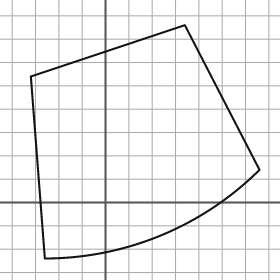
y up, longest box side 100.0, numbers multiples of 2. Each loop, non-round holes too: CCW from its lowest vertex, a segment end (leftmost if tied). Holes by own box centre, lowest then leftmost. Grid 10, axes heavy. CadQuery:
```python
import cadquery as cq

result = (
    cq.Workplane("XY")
    .moveTo(-26.0, -24.0)
    .threePointArc((24.0, -14.0), (66.0, 14.0))
    .lineTo(34.0, 76.0)
    .lineTo(-32.0, 54.0)
    .close()
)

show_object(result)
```